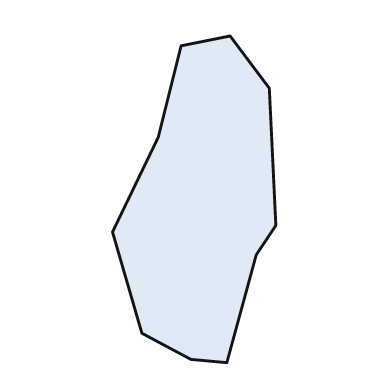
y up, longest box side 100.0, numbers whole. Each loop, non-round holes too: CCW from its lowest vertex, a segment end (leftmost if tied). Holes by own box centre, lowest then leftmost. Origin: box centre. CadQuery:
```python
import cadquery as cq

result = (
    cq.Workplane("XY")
    .moveTo(10.0, -50.0)
    .lineTo(19.0, -17.0)
    .lineTo(25.0, -8.0)
    .lineTo(23.0, 34.0)
    .lineTo(11.0, 50.0)
    .lineTo(-4.0, 47.0)
    .lineTo(-11.0, 19.0)
    .lineTo(-25.0, -10.0)
    .lineTo(-16.0, -41.0)
    .lineTo(-1.0, -49.0)
    .close()
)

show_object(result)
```